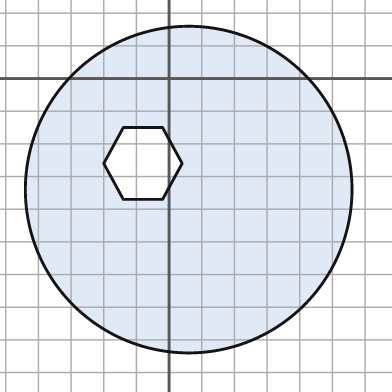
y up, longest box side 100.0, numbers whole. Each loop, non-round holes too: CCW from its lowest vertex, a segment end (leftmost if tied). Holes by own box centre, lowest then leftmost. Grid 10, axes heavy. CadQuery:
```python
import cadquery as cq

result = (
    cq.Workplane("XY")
    .moveTo(6.0, -34.0)
    .circle(50.0)
    .moveTo(-14.0, -37.0)
    .lineTo(-2.0, -37.0)
    .lineTo(4.0, -26.0)
    .lineTo(-2.0, -15.0)
    .lineTo(-14.0, -15.0)
    .lineTo(-20.0, -26.0)
    .close()
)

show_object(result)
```